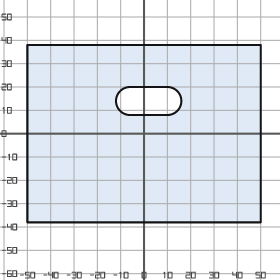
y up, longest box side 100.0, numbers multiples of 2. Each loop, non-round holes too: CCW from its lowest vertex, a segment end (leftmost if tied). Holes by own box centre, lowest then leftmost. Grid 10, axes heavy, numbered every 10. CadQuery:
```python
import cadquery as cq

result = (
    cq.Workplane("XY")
    .moveTo(-50.0, -38.0)
    .lineTo(50.0, -38.0)
    .lineTo(50.0, 38.0)
    .lineTo(-50.0, 38.0)
    .close()
    .moveTo(-6.0, 8.0)
    .lineTo(10.0, 8.0)
    .threePointArc((16.0, 14.0), (10.0, 20.0))
    .lineTo(-6.0, 20.0)
    .threePointArc((-12.0, 14.0), (-6.0, 8.0))
    .close()
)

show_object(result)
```